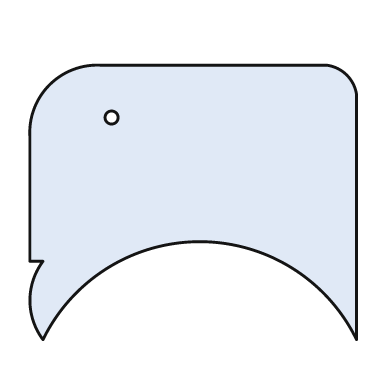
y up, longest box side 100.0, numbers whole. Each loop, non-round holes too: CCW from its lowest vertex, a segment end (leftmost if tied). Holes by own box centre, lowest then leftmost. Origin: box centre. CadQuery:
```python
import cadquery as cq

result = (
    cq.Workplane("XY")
    .moveTo(-46.0, -42.0)
    .threePointArc((2.0, -12.0), (50.0, -42.0))
    .lineTo(50.0, 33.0)
    .threePointArc((47.0, 39.0), (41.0, 42.0))
    .lineTo(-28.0, 42.0)
    .threePointArc((-44.0, 36.0), (-50.0, 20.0))
    .lineTo(-50.0, -18.0)
    .lineTo(-46.0, -18.0)
    .threePointArc((-50.0, -30.0), (-46.0, -42.0))
    .close()
    .moveTo(-25.0, 26.0)
    .circle(2.0)
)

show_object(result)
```